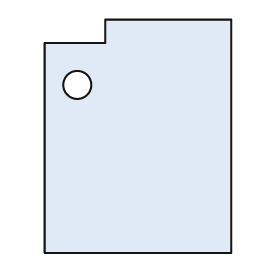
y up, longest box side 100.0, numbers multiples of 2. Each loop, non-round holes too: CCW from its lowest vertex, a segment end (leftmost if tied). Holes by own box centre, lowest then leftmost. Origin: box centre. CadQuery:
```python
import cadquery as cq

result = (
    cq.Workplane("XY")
    .moveTo(-40.0, -50.0)
    .lineTo(40.0, -50.0)
    .lineTo(40.0, 50.0)
    .lineTo(-14.0, 50.0)
    .lineTo(-14.0, 40.0)
    .lineTo(-40.0, 40.0)
    .close()
    .moveTo(-26.0, 22.0)
    .circle(6.0)
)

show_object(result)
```